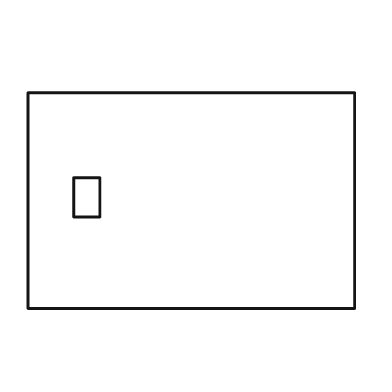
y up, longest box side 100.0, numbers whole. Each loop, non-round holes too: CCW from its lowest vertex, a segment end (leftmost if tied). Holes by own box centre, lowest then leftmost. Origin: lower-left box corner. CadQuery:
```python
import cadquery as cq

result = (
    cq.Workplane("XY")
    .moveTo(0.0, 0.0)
    .lineTo(100.0, 0.0)
    .lineTo(100.0, 66.0)
    .lineTo(0.0, 66.0)
    .close()
    .moveTo(14.0, 28.0)
    .lineTo(22.0, 28.0)
    .lineTo(22.0, 40.0)
    .lineTo(14.0, 40.0)
    .close()
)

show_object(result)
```